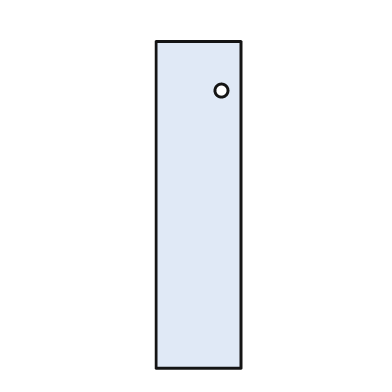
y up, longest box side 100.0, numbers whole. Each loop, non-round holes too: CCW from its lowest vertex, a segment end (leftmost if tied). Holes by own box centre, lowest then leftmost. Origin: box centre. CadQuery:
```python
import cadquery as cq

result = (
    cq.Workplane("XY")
    .moveTo(-13.0, -50.0)
    .lineTo(13.0, -50.0)
    .lineTo(13.0, 50.0)
    .lineTo(-13.0, 50.0)
    .close()
    .moveTo(7.0, 35.0)
    .circle(2.0)
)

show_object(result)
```